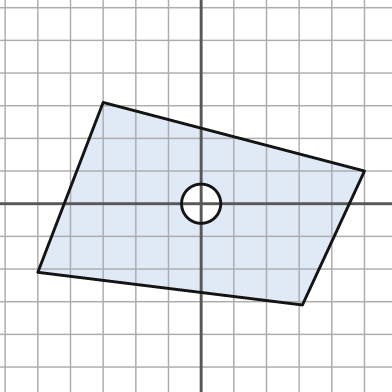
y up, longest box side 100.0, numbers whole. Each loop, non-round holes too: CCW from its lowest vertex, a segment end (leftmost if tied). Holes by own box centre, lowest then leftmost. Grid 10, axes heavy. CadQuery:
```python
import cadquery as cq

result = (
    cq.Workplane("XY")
    .moveTo(31.0, -31.0)
    .lineTo(50.0, 10.0)
    .lineTo(-30.0, 31.0)
    .lineTo(-50.0, -21.0)
    .close()
    .moveTo(0.0, 0.0)
    .circle(6.0)
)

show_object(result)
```